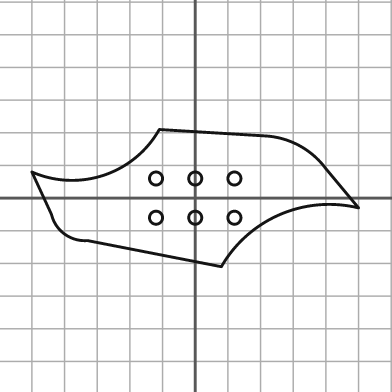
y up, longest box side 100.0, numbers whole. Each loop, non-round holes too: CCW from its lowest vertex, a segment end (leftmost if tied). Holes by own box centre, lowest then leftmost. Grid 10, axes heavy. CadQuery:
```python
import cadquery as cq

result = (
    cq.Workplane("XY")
    .moveTo(8.0, -21.0)
    .threePointArc((26.0, -5.0), (50.0, -3.0))
    .lineTo(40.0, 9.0)
    .threePointArc((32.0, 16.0), (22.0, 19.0))
    .lineTo(-11.0, 21.0)
    .threePointArc((-28.0, 7.0), (-50.0, 8.0))
    .lineTo(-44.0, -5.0)
    .threePointArc((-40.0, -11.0), (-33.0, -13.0))
    .close()
    .moveTo(-12.0, -6.0)
    .circle(2.0)
    .moveTo(0.0, -6.0)
    .circle(2.0)
    .moveTo(12.0, -6.0)
    .circle(2.0)
    .moveTo(-12.0, 6.0)
    .circle(2.0)
    .moveTo(0.0, 6.0)
    .circle(2.0)
    .moveTo(12.0, 6.0)
    .circle(2.0)
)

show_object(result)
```